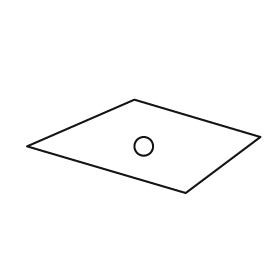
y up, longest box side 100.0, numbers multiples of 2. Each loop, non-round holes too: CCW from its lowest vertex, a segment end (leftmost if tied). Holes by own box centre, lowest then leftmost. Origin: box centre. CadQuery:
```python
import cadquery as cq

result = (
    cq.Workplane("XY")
    .moveTo(18.0, -20.0)
    .lineTo(50.0, 4.0)
    .lineTo(-4.0, 20.0)
    .lineTo(-50.0, 0.0)
    .close()
    .moveTo(0.0, 0.0)
    .circle(4.0)
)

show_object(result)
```